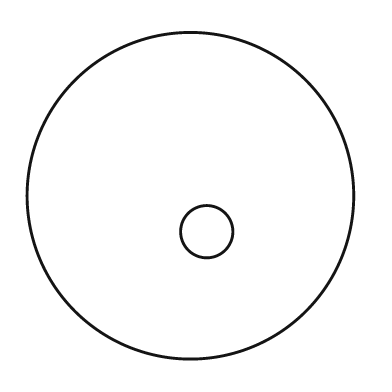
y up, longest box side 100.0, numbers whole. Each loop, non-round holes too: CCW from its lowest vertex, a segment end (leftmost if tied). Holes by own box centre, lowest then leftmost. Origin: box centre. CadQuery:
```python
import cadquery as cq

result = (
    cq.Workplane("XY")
    .moveTo(0.0, 0.0)
    .circle(50.0)
    .moveTo(5.0, -11.0)
    .circle(8.0)
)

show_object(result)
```